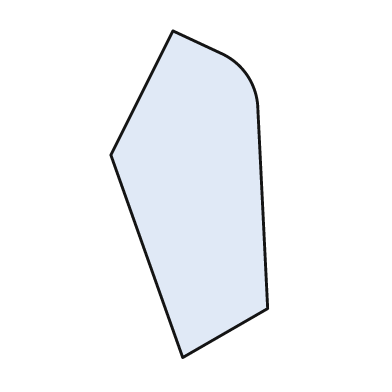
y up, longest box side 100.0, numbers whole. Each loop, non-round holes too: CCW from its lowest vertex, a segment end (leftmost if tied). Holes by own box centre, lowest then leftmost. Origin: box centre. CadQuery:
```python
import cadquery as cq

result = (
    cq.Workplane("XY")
    .moveTo(-2.0, -50.0)
    .lineTo(24.0, -35.0)
    .lineTo(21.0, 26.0)
    .threePointArc((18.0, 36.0), (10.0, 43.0))
    .lineTo(-5.0, 50.0)
    .lineTo(-24.0, 12.0)
    .close()
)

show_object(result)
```